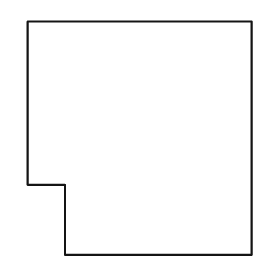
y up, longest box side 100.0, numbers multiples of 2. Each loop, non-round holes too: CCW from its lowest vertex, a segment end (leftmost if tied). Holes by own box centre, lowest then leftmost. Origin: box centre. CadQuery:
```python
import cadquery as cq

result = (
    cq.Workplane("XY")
    .moveTo(-32.0, -50.0)
    .lineTo(48.0, -50.0)
    .lineTo(48.0, 50.0)
    .lineTo(-48.0, 50.0)
    .lineTo(-48.0, -20.0)
    .lineTo(-32.0, -20.0)
    .close()
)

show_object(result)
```